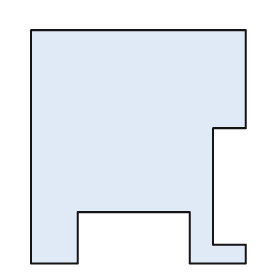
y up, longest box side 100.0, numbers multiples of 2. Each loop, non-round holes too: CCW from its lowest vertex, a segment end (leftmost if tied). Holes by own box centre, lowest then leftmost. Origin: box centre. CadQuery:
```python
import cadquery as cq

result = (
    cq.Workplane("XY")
    .moveTo(-46.0, -50.0)
    .lineTo(-26.0, -50.0)
    .lineTo(-26.0, -28.0)
    .lineTo(22.0, -28.0)
    .lineTo(22.0, -50.0)
    .lineTo(46.0, -50.0)
    .lineTo(46.0, -42.0)
    .lineTo(32.0, -42.0)
    .lineTo(32.0, 8.0)
    .lineTo(46.0, 8.0)
    .lineTo(46.0, 50.0)
    .lineTo(-46.0, 50.0)
    .close()
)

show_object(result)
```